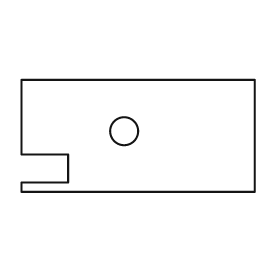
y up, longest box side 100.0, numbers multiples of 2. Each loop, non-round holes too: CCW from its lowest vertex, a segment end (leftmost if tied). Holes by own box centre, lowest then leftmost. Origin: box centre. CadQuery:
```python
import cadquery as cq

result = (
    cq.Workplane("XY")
    .moveTo(-50.0, -24.0)
    .lineTo(50.0, -24.0)
    .lineTo(50.0, 24.0)
    .lineTo(-50.0, 24.0)
    .lineTo(-50.0, -8.0)
    .lineTo(-30.0, -8.0)
    .lineTo(-30.0, -20.0)
    .lineTo(-50.0, -20.0)
    .close()
    .moveTo(-6.0, 2.0)
    .circle(6.0)
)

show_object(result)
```